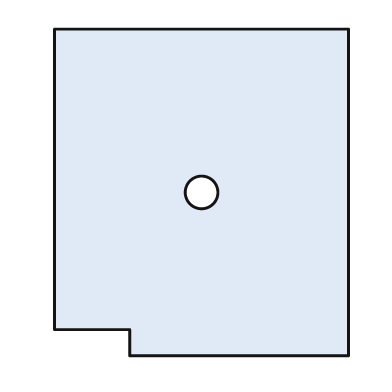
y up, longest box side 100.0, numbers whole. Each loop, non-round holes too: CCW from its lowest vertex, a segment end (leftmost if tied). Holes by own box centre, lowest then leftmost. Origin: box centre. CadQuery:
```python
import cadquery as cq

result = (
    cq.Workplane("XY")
    .moveTo(-22.0, -50.0)
    .lineTo(45.0, -50.0)
    .lineTo(45.0, 50.0)
    .lineTo(-45.0, 50.0)
    .lineTo(-45.0, -42.0)
    .lineTo(-22.0, -42.0)
    .close()
    .moveTo(0.0, 0.0)
    .circle(5.0)
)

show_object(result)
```